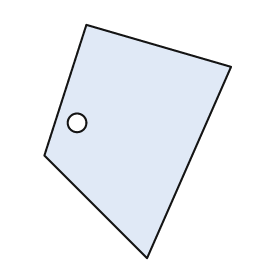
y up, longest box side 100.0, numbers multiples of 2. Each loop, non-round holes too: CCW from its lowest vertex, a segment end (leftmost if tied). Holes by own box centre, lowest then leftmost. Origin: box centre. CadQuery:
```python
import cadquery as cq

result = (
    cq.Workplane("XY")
    .moveTo(4.0, -50.0)
    .lineTo(40.0, 32.0)
    .lineTo(-22.0, 50.0)
    .lineTo(-40.0, -6.0)
    .close()
    .moveTo(-26.0, 8.0)
    .circle(4.0)
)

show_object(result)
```